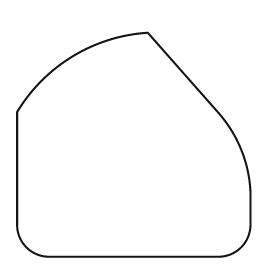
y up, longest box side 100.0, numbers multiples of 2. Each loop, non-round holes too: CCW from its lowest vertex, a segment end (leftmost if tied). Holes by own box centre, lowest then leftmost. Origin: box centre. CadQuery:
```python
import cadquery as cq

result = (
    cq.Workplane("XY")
    .moveTo(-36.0, -48.0)
    .lineTo(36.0, -48.0)
    .threePointArc((46.0, -44.0), (50.0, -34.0))
    .lineTo(50.0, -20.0)
    .threePointArc((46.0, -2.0), (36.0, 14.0))
    .lineTo(6.0, 48.0)
    .threePointArc((-26.0, 38.0), (-50.0, 14.0))
    .lineTo(-50.0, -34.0)
    .threePointArc((-46.0, -44.0), (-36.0, -48.0))
    .close()
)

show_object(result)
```